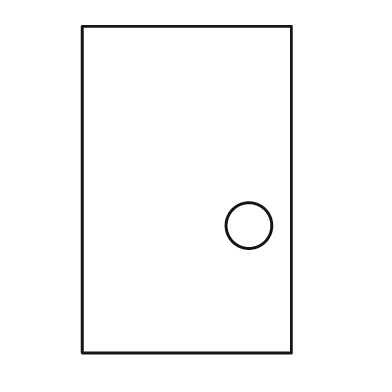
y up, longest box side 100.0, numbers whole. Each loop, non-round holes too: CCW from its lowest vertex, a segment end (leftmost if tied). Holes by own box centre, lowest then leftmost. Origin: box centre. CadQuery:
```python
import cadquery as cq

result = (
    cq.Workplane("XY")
    .moveTo(-32.0, -50.0)
    .lineTo(32.0, -50.0)
    .lineTo(32.0, 50.0)
    .lineTo(-32.0, 50.0)
    .close()
    .moveTo(19.0, -11.0)
    .circle(7.0)
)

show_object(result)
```